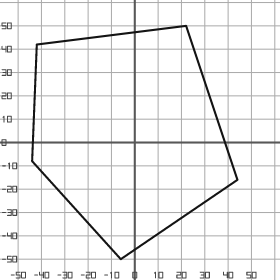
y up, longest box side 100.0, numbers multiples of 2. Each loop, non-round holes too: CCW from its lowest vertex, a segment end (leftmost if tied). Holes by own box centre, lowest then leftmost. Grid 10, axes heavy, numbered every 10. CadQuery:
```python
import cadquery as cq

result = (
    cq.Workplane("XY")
    .moveTo(-6.0, -50.0)
    .lineTo(44.0, -16.0)
    .lineTo(22.0, 50.0)
    .lineTo(-42.0, 42.0)
    .lineTo(-44.0, -8.0)
    .close()
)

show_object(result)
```